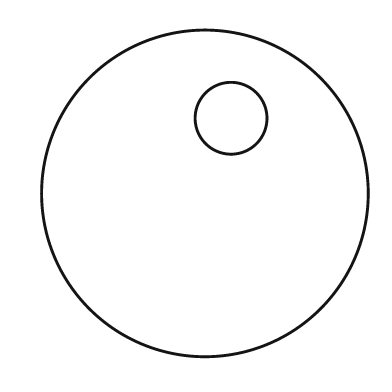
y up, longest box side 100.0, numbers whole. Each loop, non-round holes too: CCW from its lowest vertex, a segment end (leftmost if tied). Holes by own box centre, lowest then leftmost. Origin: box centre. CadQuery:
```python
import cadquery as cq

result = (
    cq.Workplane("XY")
    .moveTo(0.0, 0.0)
    .circle(50.0)
    .moveTo(8.0, 23.0)
    .circle(11.0)
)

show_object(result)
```